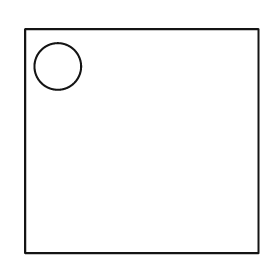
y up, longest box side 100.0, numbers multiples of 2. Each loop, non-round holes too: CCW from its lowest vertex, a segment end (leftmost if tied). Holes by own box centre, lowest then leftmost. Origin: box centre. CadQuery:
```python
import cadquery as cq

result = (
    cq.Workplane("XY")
    .moveTo(-50.0, -48.0)
    .lineTo(50.0, -48.0)
    .lineTo(50.0, 48.0)
    .lineTo(-50.0, 48.0)
    .close()
    .moveTo(-36.0, 32.0)
    .circle(10.0)
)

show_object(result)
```